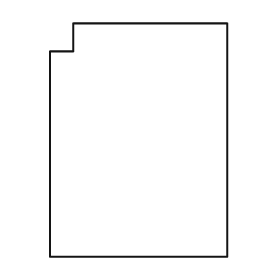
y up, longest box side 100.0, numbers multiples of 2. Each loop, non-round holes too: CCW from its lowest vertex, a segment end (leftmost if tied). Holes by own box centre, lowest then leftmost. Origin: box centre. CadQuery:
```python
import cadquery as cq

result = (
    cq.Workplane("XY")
    .moveTo(-38.0, -50.0)
    .lineTo(38.0, -50.0)
    .lineTo(38.0, 50.0)
    .lineTo(-28.0, 50.0)
    .lineTo(-28.0, 38.0)
    .lineTo(-38.0, 38.0)
    .close()
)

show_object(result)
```